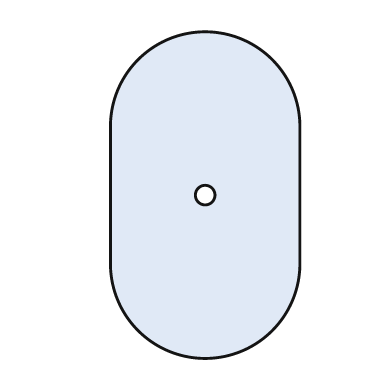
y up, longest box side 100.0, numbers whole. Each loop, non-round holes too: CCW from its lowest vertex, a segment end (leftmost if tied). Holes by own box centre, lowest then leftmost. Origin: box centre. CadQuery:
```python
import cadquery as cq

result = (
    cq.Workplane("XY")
    .moveTo(-29.0, -21.0)
    .threePointArc((0.0, -50.0), (29.0, -21.0))
    .lineTo(29.0, 21.0)
    .threePointArc((0.0, 50.0), (-29.0, 21.0))
    .close()
    .moveTo(0.0, 0.0)
    .circle(3.0)
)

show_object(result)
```